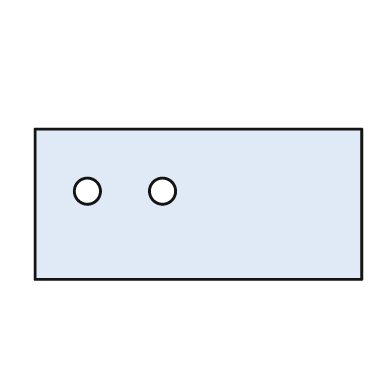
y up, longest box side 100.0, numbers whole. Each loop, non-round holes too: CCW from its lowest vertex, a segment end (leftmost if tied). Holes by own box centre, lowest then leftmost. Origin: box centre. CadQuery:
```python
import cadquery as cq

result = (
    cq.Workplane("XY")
    .moveTo(-50.0, -23.0)
    .lineTo(50.0, -23.0)
    .lineTo(50.0, 23.0)
    .lineTo(-50.0, 23.0)
    .close()
    .moveTo(-34.0, 4.0)
    .circle(4.0)
    .moveTo(-11.0, 4.0)
    .circle(4.0)
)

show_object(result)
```